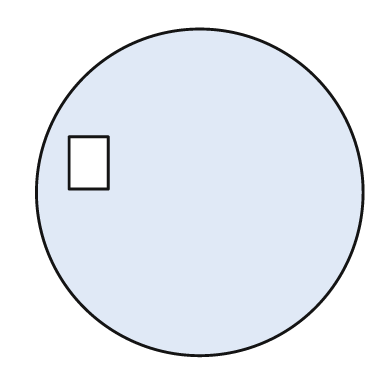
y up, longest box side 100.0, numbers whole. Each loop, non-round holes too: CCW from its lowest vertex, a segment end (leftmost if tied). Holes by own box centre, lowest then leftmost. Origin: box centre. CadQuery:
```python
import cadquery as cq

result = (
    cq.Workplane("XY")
    .moveTo(0.0, 0.0)
    .circle(50.0)
    .moveTo(-40.0, 1.0)
    .lineTo(-28.0, 1.0)
    .lineTo(-28.0, 17.0)
    .lineTo(-40.0, 17.0)
    .close()
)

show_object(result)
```